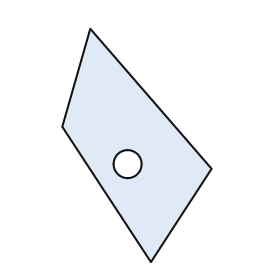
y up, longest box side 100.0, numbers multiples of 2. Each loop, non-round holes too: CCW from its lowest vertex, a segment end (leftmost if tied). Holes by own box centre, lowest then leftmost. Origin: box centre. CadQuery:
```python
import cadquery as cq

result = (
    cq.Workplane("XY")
    .moveTo(6.0, -50.0)
    .lineTo(32.0, -10.0)
    .lineTo(-20.0, 50.0)
    .lineTo(-32.0, 8.0)
    .close()
    .moveTo(-4.0, -8.0)
    .circle(6.0)
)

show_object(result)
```